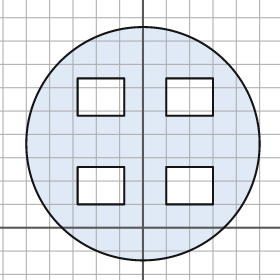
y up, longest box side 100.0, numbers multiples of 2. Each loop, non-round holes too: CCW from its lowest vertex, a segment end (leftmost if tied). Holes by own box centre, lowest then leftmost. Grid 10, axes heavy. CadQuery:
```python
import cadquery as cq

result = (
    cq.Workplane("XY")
    .moveTo(0.0, 36.0)
    .circle(50.0)
    .moveTo(-28.0, 10.0)
    .lineTo(-8.0, 10.0)
    .lineTo(-8.0, 26.0)
    .lineTo(-28.0, 26.0)
    .close()
    .moveTo(10.0, 10.0)
    .lineTo(30.0, 10.0)
    .lineTo(30.0, 26.0)
    .lineTo(10.0, 26.0)
    .close()
    .moveTo(-28.0, 48.0)
    .lineTo(-8.0, 48.0)
    .lineTo(-8.0, 64.0)
    .lineTo(-28.0, 64.0)
    .close()
    .moveTo(10.0, 48.0)
    .lineTo(30.0, 48.0)
    .lineTo(30.0, 64.0)
    .lineTo(10.0, 64.0)
    .close()
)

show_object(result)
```